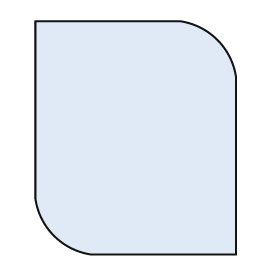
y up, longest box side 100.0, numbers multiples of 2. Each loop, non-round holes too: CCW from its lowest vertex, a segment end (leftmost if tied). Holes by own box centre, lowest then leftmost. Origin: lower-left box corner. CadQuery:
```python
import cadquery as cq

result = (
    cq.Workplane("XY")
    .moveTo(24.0, 0.0)
    .lineTo(86.0, 0.0)
    .lineTo(86.0, 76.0)
    .threePointArc((78.0, 92.0), (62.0, 100.0))
    .lineTo(0.0, 100.0)
    .lineTo(0.0, 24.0)
    .threePointArc((8.0, 8.0), (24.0, 0.0))
    .close()
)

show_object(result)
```